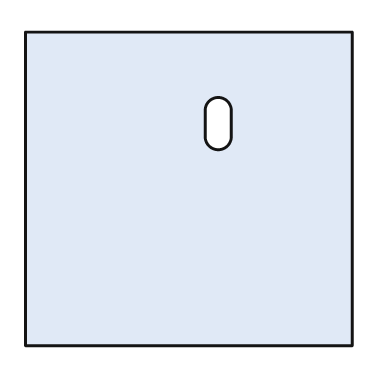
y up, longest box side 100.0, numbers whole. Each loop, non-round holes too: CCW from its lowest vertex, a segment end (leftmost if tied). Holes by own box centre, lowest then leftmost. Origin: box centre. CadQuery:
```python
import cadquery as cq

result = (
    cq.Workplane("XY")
    .moveTo(-50.0, -48.0)
    .lineTo(50.0, -48.0)
    .lineTo(50.0, 48.0)
    .lineTo(-50.0, 48.0)
    .close()
    .moveTo(5.0, 16.0)
    .threePointArc((9.0, 12.0), (13.0, 16.0))
    .lineTo(13.0, 24.0)
    .threePointArc((9.0, 28.0), (5.0, 24.0))
    .close()
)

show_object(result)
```